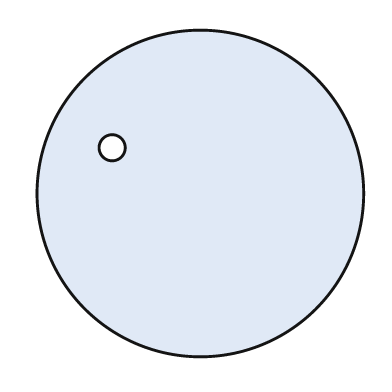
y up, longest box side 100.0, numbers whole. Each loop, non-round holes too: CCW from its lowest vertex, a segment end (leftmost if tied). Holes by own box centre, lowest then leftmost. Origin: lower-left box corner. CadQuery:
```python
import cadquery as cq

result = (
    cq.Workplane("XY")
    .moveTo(50.0, 50.0)
    .circle(50.0)
    .moveTo(23.0, 64.0)
    .circle(4.0)
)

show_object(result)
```